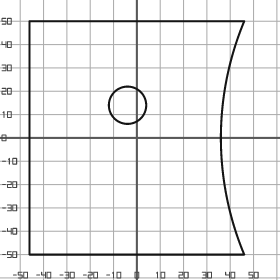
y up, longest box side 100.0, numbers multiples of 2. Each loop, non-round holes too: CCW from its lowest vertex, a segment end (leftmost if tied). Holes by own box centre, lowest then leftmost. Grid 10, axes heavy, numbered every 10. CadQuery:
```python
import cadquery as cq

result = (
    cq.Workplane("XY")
    .moveTo(-46.0, -50.0)
    .lineTo(46.0, -50.0)
    .threePointArc((36.0, 0.0), (46.0, 50.0))
    .lineTo(-46.0, 50.0)
    .close()
    .moveTo(-4.0, 14.0)
    .circle(8.0)
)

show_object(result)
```